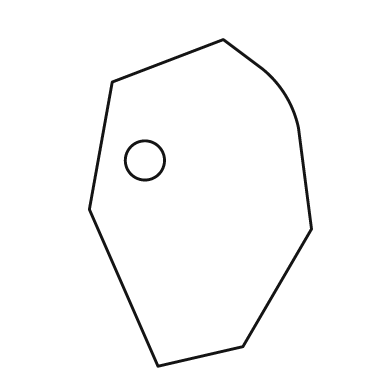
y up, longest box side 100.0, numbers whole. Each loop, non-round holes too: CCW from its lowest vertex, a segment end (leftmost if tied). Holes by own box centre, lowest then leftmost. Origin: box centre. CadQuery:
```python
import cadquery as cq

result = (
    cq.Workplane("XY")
    .moveTo(-13.0, -50.0)
    .lineTo(13.0, -44.0)
    .lineTo(34.0, -8.0)
    .lineTo(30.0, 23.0)
    .threePointArc((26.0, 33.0), (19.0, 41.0))
    .lineTo(7.0, 50.0)
    .lineTo(-27.0, 37.0)
    .lineTo(-34.0, -2.0)
    .close()
    .moveTo(-17.0, 13.0)
    .circle(6.0)
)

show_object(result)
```